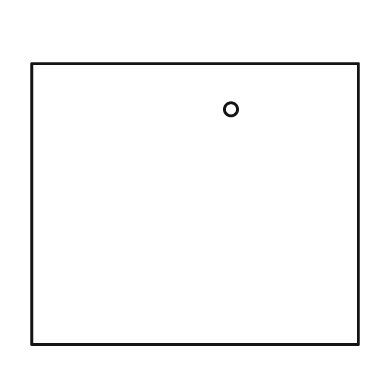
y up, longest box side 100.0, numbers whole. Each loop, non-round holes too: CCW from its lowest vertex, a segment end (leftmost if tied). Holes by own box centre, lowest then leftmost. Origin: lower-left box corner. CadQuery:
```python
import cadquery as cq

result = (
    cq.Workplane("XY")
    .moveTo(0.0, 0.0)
    .lineTo(100.0, 0.0)
    .lineTo(100.0, 86.0)
    .lineTo(0.0, 86.0)
    .close()
    .moveTo(61.0, 72.0)
    .circle(2.0)
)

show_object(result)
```